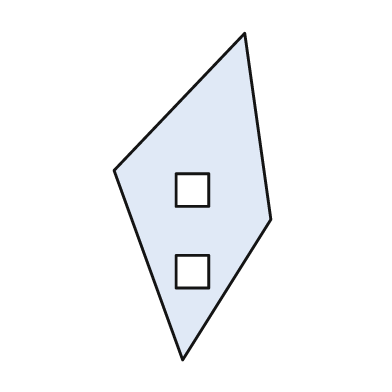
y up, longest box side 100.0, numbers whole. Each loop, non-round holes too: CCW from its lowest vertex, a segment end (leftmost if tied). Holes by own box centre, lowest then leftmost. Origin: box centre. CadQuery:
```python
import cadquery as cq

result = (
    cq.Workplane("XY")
    .moveTo(-3.0, -50.0)
    .lineTo(24.0, -7.0)
    .lineTo(16.0, 50.0)
    .lineTo(-24.0, 8.0)
    .close()
    .moveTo(-5.0, -28.0)
    .lineTo(5.0, -28.0)
    .lineTo(5.0, -18.0)
    .lineTo(-5.0, -18.0)
    .close()
    .moveTo(-5.0, -3.0)
    .lineTo(5.0, -3.0)
    .lineTo(5.0, 7.0)
    .lineTo(-5.0, 7.0)
    .close()
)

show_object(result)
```